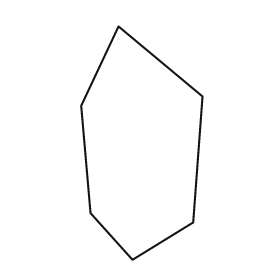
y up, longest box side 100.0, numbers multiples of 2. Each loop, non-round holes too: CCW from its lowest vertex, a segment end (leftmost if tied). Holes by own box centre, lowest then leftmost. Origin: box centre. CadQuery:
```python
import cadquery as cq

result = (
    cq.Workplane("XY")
    .moveTo(-4.0, -50.0)
    .lineTo(22.0, -34.0)
    .lineTo(26.0, 20.0)
    .lineTo(-10.0, 50.0)
    .lineTo(-26.0, 16.0)
    .lineTo(-22.0, -30.0)
    .close()
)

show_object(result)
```